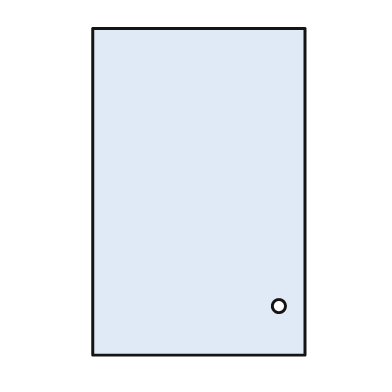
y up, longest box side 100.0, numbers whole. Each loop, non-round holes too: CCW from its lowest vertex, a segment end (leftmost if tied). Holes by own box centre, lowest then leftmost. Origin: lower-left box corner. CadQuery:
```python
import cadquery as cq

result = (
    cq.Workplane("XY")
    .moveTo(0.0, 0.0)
    .lineTo(65.0, 0.0)
    .lineTo(65.0, 100.0)
    .lineTo(0.0, 100.0)
    .close()
    .moveTo(57.0, 15.0)
    .circle(2.0)
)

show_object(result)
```